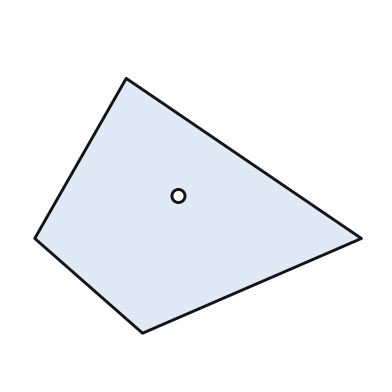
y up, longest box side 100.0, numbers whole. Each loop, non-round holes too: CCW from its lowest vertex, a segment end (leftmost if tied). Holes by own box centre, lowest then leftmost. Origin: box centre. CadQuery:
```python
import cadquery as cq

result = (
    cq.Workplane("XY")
    .moveTo(-17.0, -39.0)
    .lineTo(50.0, -10.0)
    .lineTo(-22.0, 39.0)
    .lineTo(-50.0, -10.0)
    .close()
    .moveTo(-6.0, 3.0)
    .circle(2.0)
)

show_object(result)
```